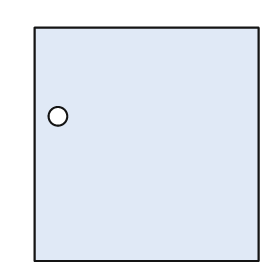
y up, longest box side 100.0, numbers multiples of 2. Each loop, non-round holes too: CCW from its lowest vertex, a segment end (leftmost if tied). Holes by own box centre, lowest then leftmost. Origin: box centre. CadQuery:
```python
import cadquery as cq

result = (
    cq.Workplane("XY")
    .moveTo(-48.0, -50.0)
    .lineTo(48.0, -50.0)
    .lineTo(48.0, 50.0)
    .lineTo(-48.0, 50.0)
    .close()
    .moveTo(-38.0, 12.0)
    .circle(4.0)
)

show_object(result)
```